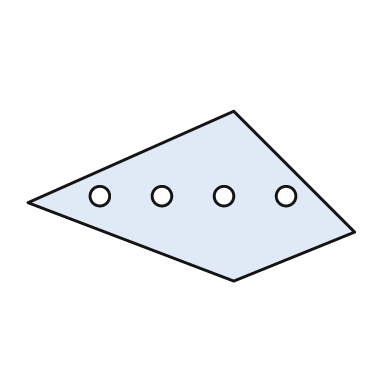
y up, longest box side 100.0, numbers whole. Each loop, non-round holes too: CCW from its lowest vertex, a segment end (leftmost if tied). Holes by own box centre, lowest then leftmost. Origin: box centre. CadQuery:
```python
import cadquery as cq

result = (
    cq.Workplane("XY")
    .moveTo(13.0, -26.0)
    .lineTo(50.0, -11.0)
    .lineTo(13.0, 26.0)
    .lineTo(-50.0, -2.0)
    .close()
    .moveTo(-28.0, 0.0)
    .circle(3.0)
    .moveTo(-9.0, 0.0)
    .circle(3.0)
    .moveTo(10.0, 0.0)
    .circle(3.0)
    .moveTo(29.0, 0.0)
    .circle(3.0)
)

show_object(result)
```